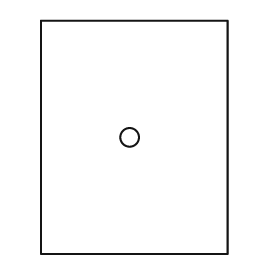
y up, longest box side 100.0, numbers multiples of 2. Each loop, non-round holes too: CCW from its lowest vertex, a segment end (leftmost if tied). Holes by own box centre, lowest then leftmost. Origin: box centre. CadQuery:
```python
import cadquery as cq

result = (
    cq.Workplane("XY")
    .moveTo(-40.0, -50.0)
    .lineTo(40.0, -50.0)
    .lineTo(40.0, 50.0)
    .lineTo(-40.0, 50.0)
    .close()
    .moveTo(-2.0, 0.0)
    .circle(4.0)
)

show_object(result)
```